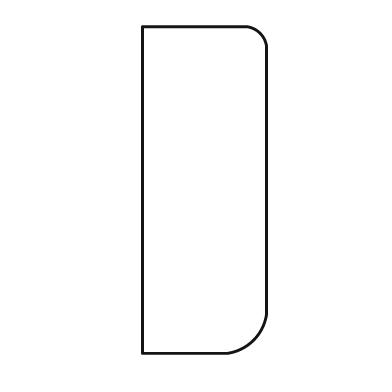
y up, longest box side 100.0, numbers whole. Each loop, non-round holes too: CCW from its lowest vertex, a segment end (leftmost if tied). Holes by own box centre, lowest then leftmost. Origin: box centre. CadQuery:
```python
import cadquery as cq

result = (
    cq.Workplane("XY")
    .moveTo(-19.0, -50.0)
    .lineTo(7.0, -50.0)
    .threePointArc((15.0, -46.0), (19.0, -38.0))
    .lineTo(19.0, 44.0)
    .threePointArc((17.0, 48.0), (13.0, 50.0))
    .lineTo(-19.0, 50.0)
    .close()
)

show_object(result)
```